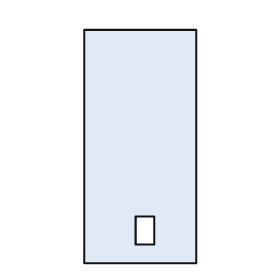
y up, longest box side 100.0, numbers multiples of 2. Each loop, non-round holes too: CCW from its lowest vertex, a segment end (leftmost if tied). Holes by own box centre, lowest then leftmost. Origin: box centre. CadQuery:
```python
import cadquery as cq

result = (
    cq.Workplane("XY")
    .moveTo(-24.0, -50.0)
    .lineTo(24.0, -50.0)
    .lineTo(24.0, 50.0)
    .lineTo(-24.0, 50.0)
    .close()
    .moveTo(-2.0, -42.0)
    .lineTo(6.0, -42.0)
    .lineTo(6.0, -30.0)
    .lineTo(-2.0, -30.0)
    .close()
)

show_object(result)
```